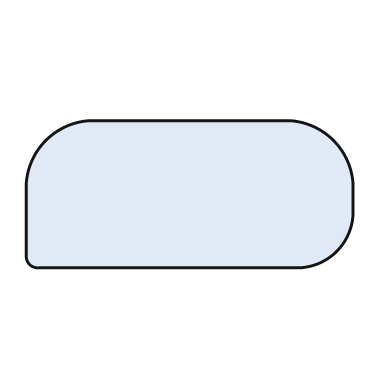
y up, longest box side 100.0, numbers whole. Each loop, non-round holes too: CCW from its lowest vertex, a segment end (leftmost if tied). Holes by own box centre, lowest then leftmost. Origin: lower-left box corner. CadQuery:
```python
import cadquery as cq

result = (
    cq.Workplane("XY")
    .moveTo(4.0, 0.0)
    .lineTo(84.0, 0.0)
    .threePointArc((95.0, 5.0), (100.0, 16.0))
    .lineTo(100.0, 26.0)
    .threePointArc((94.0, 39.0), (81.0, 45.0))
    .lineTo(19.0, 45.0)
    .threePointArc((6.0, 39.0), (0.0, 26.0))
    .lineTo(0.0, 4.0)
    .threePointArc((1.0, 1.0), (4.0, 0.0))
    .close()
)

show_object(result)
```